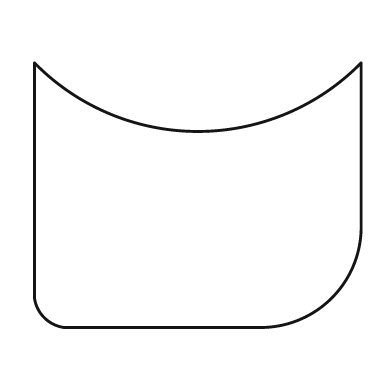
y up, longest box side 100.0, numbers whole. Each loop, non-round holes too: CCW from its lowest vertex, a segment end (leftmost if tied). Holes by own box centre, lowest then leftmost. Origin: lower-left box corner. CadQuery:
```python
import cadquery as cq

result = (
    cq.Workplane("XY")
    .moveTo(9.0, 0.0)
    .lineTo(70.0, 0.0)
    .threePointArc((91.0, 9.0), (100.0, 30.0))
    .lineTo(100.0, 81.0)
    .threePointArc((50.0, 60.0), (0.0, 81.0))
    .lineTo(0.0, 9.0)
    .threePointArc((3.0, 3.0), (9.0, 0.0))
    .close()
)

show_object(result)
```